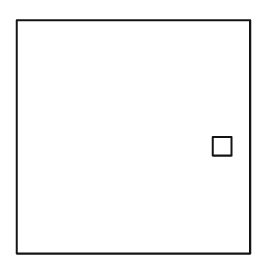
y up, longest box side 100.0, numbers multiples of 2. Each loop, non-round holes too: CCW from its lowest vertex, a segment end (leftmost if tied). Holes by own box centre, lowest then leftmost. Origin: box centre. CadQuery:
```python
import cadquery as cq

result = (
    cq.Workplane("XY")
    .moveTo(-50.0, -50.0)
    .lineTo(50.0, -50.0)
    .lineTo(50.0, 50.0)
    .lineTo(-50.0, 50.0)
    .close()
    .moveTo(34.0, -8.0)
    .lineTo(42.0, -8.0)
    .lineTo(42.0, 0.0)
    .lineTo(34.0, 0.0)
    .close()
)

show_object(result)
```